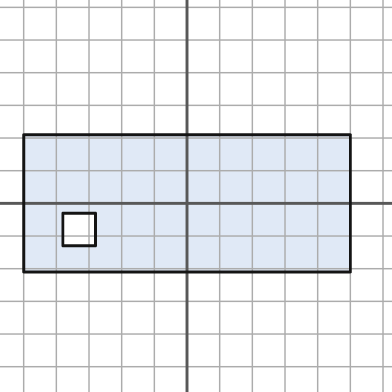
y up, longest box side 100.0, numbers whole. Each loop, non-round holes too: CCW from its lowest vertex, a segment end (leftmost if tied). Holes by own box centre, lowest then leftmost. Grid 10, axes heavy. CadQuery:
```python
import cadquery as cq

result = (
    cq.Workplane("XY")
    .moveTo(-50.0, -21.0)
    .lineTo(50.0, -21.0)
    .lineTo(50.0, 21.0)
    .lineTo(-50.0, 21.0)
    .close()
    .moveTo(-38.0, -13.0)
    .lineTo(-28.0, -13.0)
    .lineTo(-28.0, -3.0)
    .lineTo(-38.0, -3.0)
    .close()
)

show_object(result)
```